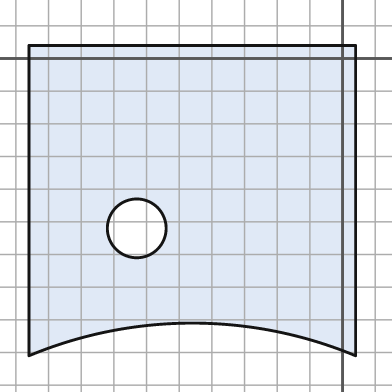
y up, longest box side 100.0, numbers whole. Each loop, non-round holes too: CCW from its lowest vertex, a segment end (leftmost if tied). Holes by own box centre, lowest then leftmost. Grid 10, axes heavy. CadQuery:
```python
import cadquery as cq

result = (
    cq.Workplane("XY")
    .moveTo(-96.0, -91.0)
    .threePointArc((-46.0, -81.0), (4.0, -91.0))
    .lineTo(4.0, 4.0)
    .lineTo(-96.0, 4.0)
    .close()
    .moveTo(-63.0, -52.0)
    .circle(9.0)
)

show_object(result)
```